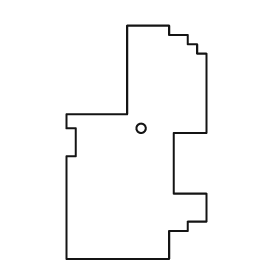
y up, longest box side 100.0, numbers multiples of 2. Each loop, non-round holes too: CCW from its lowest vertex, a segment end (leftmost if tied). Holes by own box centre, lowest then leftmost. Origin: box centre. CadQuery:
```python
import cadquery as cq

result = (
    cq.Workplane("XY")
    .moveTo(-30.0, -50.0)
    .lineTo(14.0, -50.0)
    .lineTo(14.0, -38.0)
    .lineTo(22.0, -38.0)
    .lineTo(22.0, -34.0)
    .lineTo(30.0, -34.0)
    .lineTo(30.0, -22.0)
    .lineTo(16.0, -22.0)
    .lineTo(16.0, 4.0)
    .lineTo(30.0, 4.0)
    .lineTo(30.0, 38.0)
    .lineTo(26.0, 38.0)
    .lineTo(26.0, 42.0)
    .lineTo(22.0, 42.0)
    .lineTo(22.0, 46.0)
    .lineTo(14.0, 46.0)
    .lineTo(14.0, 50.0)
    .lineTo(-4.0, 50.0)
    .lineTo(-4.0, 12.0)
    .lineTo(-30.0, 12.0)
    .lineTo(-30.0, 6.0)
    .lineTo(-26.0, 6.0)
    .lineTo(-26.0, -6.0)
    .lineTo(-30.0, -6.0)
    .close()
    .moveTo(2.0, 6.0)
    .circle(2.0)
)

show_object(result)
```